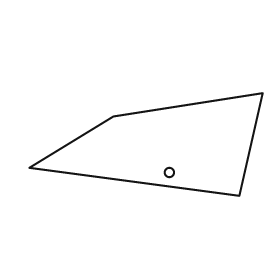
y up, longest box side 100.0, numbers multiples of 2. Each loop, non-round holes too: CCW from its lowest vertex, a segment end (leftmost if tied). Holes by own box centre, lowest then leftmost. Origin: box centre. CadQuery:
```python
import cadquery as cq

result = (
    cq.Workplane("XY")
    .moveTo(40.0, -22.0)
    .lineTo(50.0, 22.0)
    .lineTo(-14.0, 12.0)
    .lineTo(-50.0, -10.0)
    .close()
    .moveTo(10.0, -12.0)
    .circle(2.0)
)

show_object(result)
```